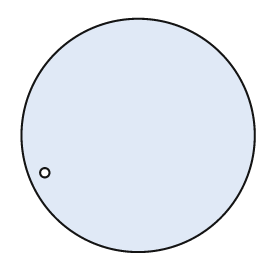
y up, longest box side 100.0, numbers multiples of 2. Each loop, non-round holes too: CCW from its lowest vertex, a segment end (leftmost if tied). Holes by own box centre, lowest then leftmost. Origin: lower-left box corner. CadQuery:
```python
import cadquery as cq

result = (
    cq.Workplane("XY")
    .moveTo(50.0, 50.0)
    .circle(50.0)
    .moveTo(10.0, 34.0)
    .circle(2.0)
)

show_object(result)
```